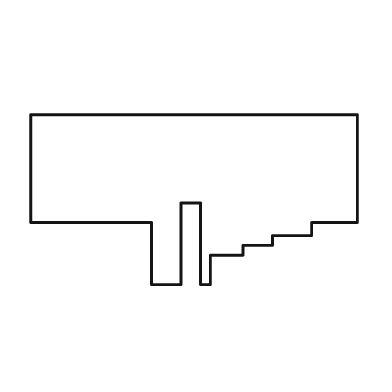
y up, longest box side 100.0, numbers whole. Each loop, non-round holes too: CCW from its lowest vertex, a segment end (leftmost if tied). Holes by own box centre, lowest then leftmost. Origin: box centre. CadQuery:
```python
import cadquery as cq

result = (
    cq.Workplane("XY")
    .moveTo(-13.0, -26.0)
    .lineTo(-4.0, -26.0)
    .lineTo(-4.0, -1.0)
    .lineTo(2.0, -1.0)
    .lineTo(2.0, -26.0)
    .lineTo(5.0, -26.0)
    .lineTo(5.0, -17.0)
    .lineTo(15.0, -17.0)
    .lineTo(15.0, -14.0)
    .lineTo(24.0, -14.0)
    .lineTo(24.0, -11.0)
    .lineTo(36.0, -11.0)
    .lineTo(36.0, -7.0)
    .lineTo(50.0, -7.0)
    .lineTo(50.0, 26.0)
    .lineTo(-50.0, 26.0)
    .lineTo(-50.0, -7.0)
    .lineTo(-13.0, -7.0)
    .close()
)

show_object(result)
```